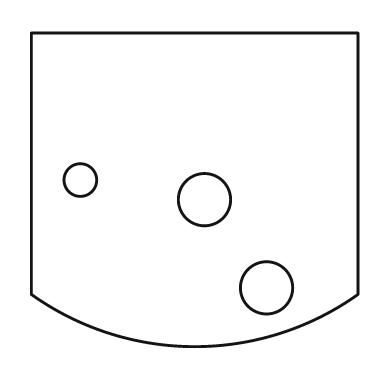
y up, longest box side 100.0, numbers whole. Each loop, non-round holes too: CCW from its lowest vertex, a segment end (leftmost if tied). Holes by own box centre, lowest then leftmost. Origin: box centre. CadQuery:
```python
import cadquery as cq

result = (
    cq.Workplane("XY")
    .moveTo(-50.0, -32.0)
    .threePointArc((0.0, -48.0), (50.0, -32.0))
    .lineTo(50.0, 48.0)
    .lineTo(-50.0, 48.0)
    .close()
    .moveTo(22.0, -30.0)
    .circle(8.0)
    .moveTo(3.0, -3.0)
    .circle(8.0)
    .moveTo(-35.0, 3.0)
    .circle(5.0)
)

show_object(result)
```